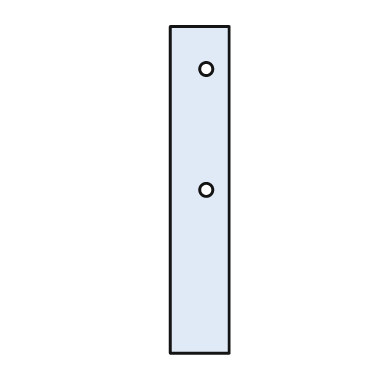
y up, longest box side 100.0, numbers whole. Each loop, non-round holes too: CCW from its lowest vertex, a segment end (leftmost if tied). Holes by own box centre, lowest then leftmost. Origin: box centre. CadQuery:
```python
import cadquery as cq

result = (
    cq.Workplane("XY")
    .moveTo(-9.0, -50.0)
    .lineTo(9.0, -50.0)
    .lineTo(9.0, 50.0)
    .lineTo(-9.0, 50.0)
    .close()
    .moveTo(2.0, 0.0)
    .circle(2.0)
    .moveTo(2.0, 37.0)
    .circle(2.0)
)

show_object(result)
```